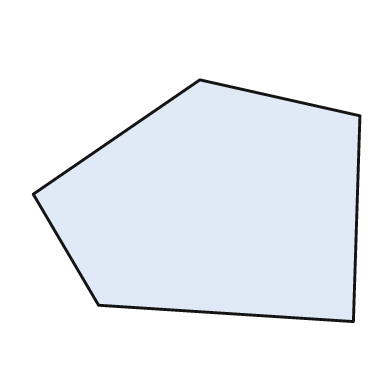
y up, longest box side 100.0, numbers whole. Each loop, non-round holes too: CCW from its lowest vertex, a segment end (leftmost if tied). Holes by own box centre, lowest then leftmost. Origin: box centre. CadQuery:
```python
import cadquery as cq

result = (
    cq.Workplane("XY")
    .moveTo(48.0, -37.0)
    .lineTo(50.0, 26.0)
    .lineTo(1.0, 37.0)
    .lineTo(-50.0, 2.0)
    .lineTo(-30.0, -32.0)
    .close()
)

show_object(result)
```